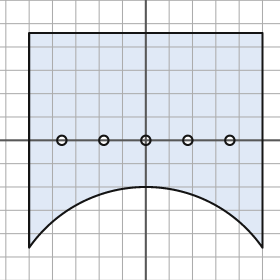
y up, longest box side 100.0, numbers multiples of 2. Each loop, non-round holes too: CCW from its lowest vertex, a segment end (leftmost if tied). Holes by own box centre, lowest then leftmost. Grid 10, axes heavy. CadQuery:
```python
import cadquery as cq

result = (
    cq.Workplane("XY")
    .moveTo(-50.0, -46.0)
    .threePointArc((0.0, -20.0), (50.0, -46.0))
    .lineTo(50.0, 46.0)
    .lineTo(-50.0, 46.0)
    .close()
    .moveTo(-36.0, 0.0)
    .circle(2.0)
    .moveTo(-18.0, 0.0)
    .circle(2.0)
    .moveTo(0.0, 0.0)
    .circle(2.0)
    .moveTo(18.0, 0.0)
    .circle(2.0)
    .moveTo(36.0, 0.0)
    .circle(2.0)
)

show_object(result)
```